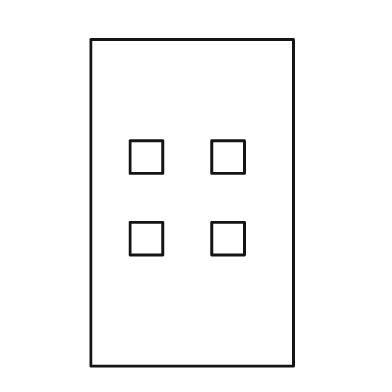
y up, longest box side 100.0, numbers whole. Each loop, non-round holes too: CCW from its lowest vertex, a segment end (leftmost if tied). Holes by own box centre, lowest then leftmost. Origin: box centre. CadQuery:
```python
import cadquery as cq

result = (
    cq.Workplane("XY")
    .moveTo(-31.0, -50.0)
    .lineTo(31.0, -50.0)
    .lineTo(31.0, 50.0)
    .lineTo(-31.0, 50.0)
    .close()
    .moveTo(-19.0, -16.0)
    .lineTo(-9.0, -16.0)
    .lineTo(-9.0, -6.0)
    .lineTo(-19.0, -6.0)
    .close()
    .moveTo(6.0, -16.0)
    .lineTo(16.0, -16.0)
    .lineTo(16.0, -6.0)
    .lineTo(6.0, -6.0)
    .close()
    .moveTo(-19.0, 9.0)
    .lineTo(-9.0, 9.0)
    .lineTo(-9.0, 19.0)
    .lineTo(-19.0, 19.0)
    .close()
    .moveTo(6.0, 9.0)
    .lineTo(16.0, 9.0)
    .lineTo(16.0, 19.0)
    .lineTo(6.0, 19.0)
    .close()
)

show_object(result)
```